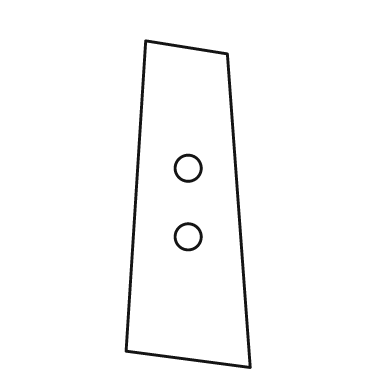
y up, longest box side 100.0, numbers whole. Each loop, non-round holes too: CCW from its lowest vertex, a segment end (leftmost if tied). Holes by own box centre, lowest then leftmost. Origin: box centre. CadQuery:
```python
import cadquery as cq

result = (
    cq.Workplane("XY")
    .moveTo(19.0, -50.0)
    .lineTo(12.0, 46.0)
    .lineTo(-13.0, 50.0)
    .lineTo(-19.0, -45.0)
    .close()
    .moveTo(0.0, -10.0)
    .circle(4.0)
    .moveTo(0.0, 11.0)
    .circle(4.0)
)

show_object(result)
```